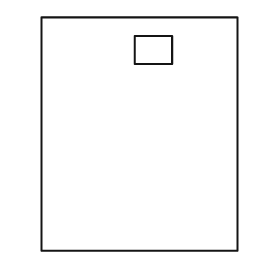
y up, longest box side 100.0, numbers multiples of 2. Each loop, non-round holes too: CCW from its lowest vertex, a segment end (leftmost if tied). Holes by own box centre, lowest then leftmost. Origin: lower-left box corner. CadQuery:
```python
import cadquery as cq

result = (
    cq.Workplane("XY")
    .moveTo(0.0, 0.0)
    .lineTo(84.0, 0.0)
    .lineTo(84.0, 100.0)
    .lineTo(0.0, 100.0)
    .close()
    .moveTo(40.0, 80.0)
    .lineTo(56.0, 80.0)
    .lineTo(56.0, 92.0)
    .lineTo(40.0, 92.0)
    .close()
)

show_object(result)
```